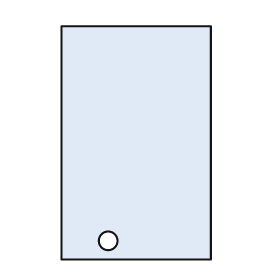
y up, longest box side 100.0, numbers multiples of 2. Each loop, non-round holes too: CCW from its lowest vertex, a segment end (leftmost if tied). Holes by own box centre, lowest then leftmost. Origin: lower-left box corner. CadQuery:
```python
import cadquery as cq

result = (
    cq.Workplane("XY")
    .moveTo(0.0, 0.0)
    .lineTo(64.0, 0.0)
    .lineTo(64.0, 100.0)
    .lineTo(0.0, 100.0)
    .close()
    .moveTo(20.0, 8.0)
    .circle(4.0)
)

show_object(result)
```